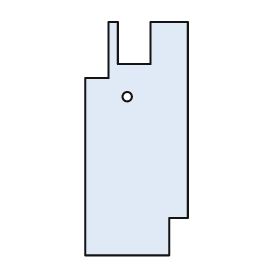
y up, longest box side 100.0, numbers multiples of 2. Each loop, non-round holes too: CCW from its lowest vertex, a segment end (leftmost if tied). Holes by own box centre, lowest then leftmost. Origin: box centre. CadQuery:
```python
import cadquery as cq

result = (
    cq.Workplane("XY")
    .moveTo(-22.0, -50.0)
    .lineTo(14.0, -50.0)
    .lineTo(14.0, -34.0)
    .lineTo(22.0, -34.0)
    .lineTo(22.0, 50.0)
    .lineTo(6.0, 50.0)
    .lineTo(6.0, 32.0)
    .lineTo(-8.0, 32.0)
    .lineTo(-8.0, 50.0)
    .lineTo(-12.0, 50.0)
    .lineTo(-12.0, 26.0)
    .lineTo(-22.0, 26.0)
    .close()
    .moveTo(-4.0, 18.0)
    .circle(2.0)
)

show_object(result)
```